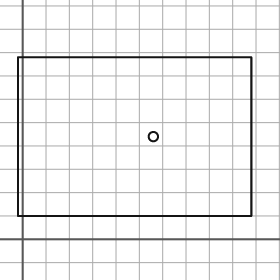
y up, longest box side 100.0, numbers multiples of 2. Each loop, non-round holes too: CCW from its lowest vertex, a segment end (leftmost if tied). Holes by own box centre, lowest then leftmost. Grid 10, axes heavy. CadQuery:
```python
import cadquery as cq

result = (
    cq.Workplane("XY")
    .moveTo(-2.0, 10.0)
    .lineTo(98.0, 10.0)
    .lineTo(98.0, 78.0)
    .lineTo(-2.0, 78.0)
    .close()
    .moveTo(56.0, 44.0)
    .circle(2.0)
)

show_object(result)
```